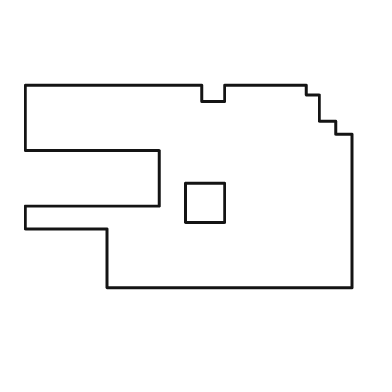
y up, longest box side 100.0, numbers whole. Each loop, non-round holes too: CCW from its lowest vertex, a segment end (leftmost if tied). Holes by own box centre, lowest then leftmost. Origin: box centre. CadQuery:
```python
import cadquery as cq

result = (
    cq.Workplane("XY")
    .moveTo(-25.0, -31.0)
    .lineTo(50.0, -31.0)
    .lineTo(50.0, 16.0)
    .lineTo(45.0, 16.0)
    .lineTo(45.0, 20.0)
    .lineTo(40.0, 20.0)
    .lineTo(40.0, 28.0)
    .lineTo(36.0, 28.0)
    .lineTo(36.0, 31.0)
    .lineTo(11.0, 31.0)
    .lineTo(11.0, 26.0)
    .lineTo(4.0, 26.0)
    .lineTo(4.0, 31.0)
    .lineTo(-50.0, 31.0)
    .lineTo(-50.0, 11.0)
    .lineTo(-9.0, 11.0)
    .lineTo(-9.0, -6.0)
    .lineTo(-50.0, -6.0)
    .lineTo(-50.0, -13.0)
    .lineTo(-25.0, -13.0)
    .close()
    .moveTo(-1.0, -11.0)
    .lineTo(11.0, -11.0)
    .lineTo(11.0, 1.0)
    .lineTo(-1.0, 1.0)
    .close()
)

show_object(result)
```